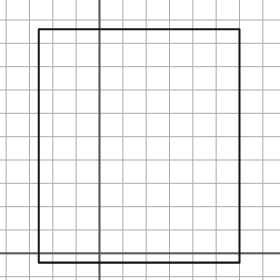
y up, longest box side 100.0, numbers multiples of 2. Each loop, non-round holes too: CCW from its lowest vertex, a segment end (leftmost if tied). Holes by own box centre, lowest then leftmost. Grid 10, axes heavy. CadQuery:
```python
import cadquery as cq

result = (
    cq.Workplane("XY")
    .moveTo(-26.0, -4.0)
    .lineTo(60.0, -4.0)
    .lineTo(60.0, 96.0)
    .lineTo(-26.0, 96.0)
    .close()
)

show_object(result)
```